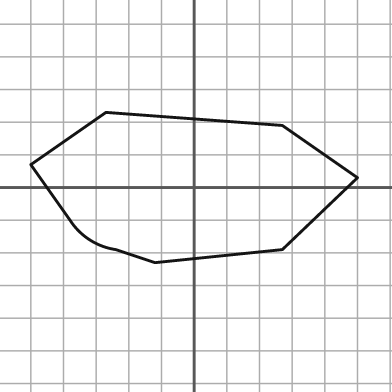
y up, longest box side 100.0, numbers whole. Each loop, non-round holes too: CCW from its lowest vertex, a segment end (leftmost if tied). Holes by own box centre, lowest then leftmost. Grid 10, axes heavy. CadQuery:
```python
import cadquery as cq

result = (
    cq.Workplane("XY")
    .moveTo(-12.0, -23.0)
    .lineTo(27.0, -19.0)
    .lineTo(50.0, 3.0)
    .lineTo(27.0, 19.0)
    .lineTo(-27.0, 23.0)
    .lineTo(-50.0, 7.0)
    .lineTo(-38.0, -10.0)
    .threePointArc((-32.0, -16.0), (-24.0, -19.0))
    .close()
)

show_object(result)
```